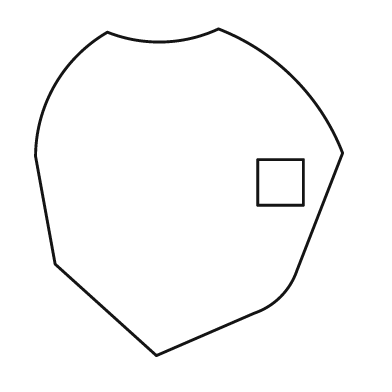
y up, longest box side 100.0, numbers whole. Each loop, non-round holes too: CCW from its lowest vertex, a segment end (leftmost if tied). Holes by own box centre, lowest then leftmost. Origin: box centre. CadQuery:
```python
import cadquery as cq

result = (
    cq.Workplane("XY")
    .moveTo(-10.0, -50.0)
    .lineTo(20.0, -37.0)
    .threePointArc((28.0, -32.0), (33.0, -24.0))
    .lineTo(47.0, 12.0)
    .threePointArc((32.0, 35.0), (9.0, 50.0))
    .threePointArc((-8.0, 46.0), (-25.0, 49.0))
    .threePointArc((-41.0, 33.0), (-47.0, 11.0))
    .lineTo(-41.0, -22.0)
    .close()
    .moveTo(21.0, -4.0)
    .lineTo(35.0, -4.0)
    .lineTo(35.0, 10.0)
    .lineTo(21.0, 10.0)
    .close()
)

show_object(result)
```